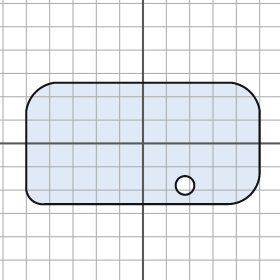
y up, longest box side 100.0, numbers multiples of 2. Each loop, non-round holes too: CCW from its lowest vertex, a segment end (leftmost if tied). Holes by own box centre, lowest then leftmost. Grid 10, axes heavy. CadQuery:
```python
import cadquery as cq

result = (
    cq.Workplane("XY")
    .moveTo(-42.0, -26.0)
    .lineTo(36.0, -26.0)
    .threePointArc((46.0, -22.0), (50.0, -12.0))
    .lineTo(50.0, 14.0)
    .threePointArc((46.0, 22.0), (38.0, 26.0))
    .lineTo(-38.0, 26.0)
    .threePointArc((-46.0, 22.0), (-50.0, 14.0))
    .lineTo(-50.0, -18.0)
    .threePointArc((-48.0, -24.0), (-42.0, -26.0))
    .close()
    .moveTo(18.0, -18.0)
    .circle(4.0)
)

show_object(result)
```